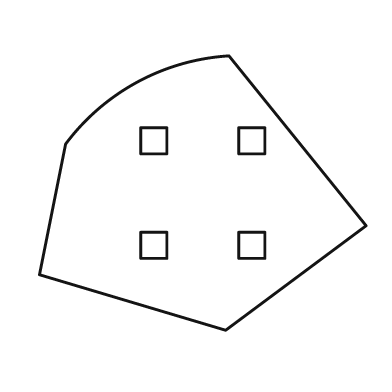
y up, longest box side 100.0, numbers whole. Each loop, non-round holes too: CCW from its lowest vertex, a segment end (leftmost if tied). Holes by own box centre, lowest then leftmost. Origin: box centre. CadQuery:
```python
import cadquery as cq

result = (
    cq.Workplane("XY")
    .moveTo(7.0, -42.0)
    .lineTo(50.0, -10.0)
    .lineTo(8.0, 42.0)
    .threePointArc((-20.0, 34.0), (-42.0, 15.0))
    .lineTo(-50.0, -25.0)
    .close()
    .moveTo(-19.0, -20.0)
    .lineTo(-11.0, -20.0)
    .lineTo(-11.0, -12.0)
    .lineTo(-19.0, -12.0)
    .close()
    .moveTo(11.0, -20.0)
    .lineTo(19.0, -20.0)
    .lineTo(19.0, -12.0)
    .lineTo(11.0, -12.0)
    .close()
    .moveTo(-19.0, 12.0)
    .lineTo(-11.0, 12.0)
    .lineTo(-11.0, 20.0)
    .lineTo(-19.0, 20.0)
    .close()
    .moveTo(11.0, 12.0)
    .lineTo(19.0, 12.0)
    .lineTo(19.0, 20.0)
    .lineTo(11.0, 20.0)
    .close()
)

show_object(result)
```